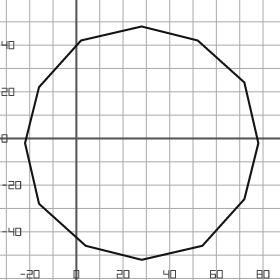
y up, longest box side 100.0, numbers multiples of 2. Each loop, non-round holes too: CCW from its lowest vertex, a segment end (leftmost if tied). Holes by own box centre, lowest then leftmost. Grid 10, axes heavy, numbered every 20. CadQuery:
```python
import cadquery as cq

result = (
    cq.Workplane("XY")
    .moveTo(28.0, -52.0)
    .lineTo(54.0, -46.0)
    .lineTo(72.0, -26.0)
    .lineTo(78.0, -2.0)
    .lineTo(72.0, 24.0)
    .lineTo(52.0, 42.0)
    .lineTo(28.0, 48.0)
    .lineTo(2.0, 42.0)
    .lineTo(-16.0, 22.0)
    .lineTo(-22.0, -2.0)
    .lineTo(-16.0, -28.0)
    .lineTo(4.0, -46.0)
    .close()
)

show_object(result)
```